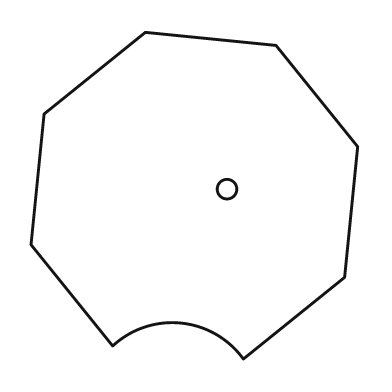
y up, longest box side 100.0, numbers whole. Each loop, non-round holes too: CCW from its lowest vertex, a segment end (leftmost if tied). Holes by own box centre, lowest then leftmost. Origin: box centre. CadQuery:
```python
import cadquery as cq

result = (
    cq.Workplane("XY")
    .moveTo(15.0, -50.0)
    .lineTo(46.0, -25.0)
    .lineTo(50.0, 15.0)
    .lineTo(25.0, 46.0)
    .lineTo(-15.0, 50.0)
    .lineTo(-46.0, 25.0)
    .lineTo(-50.0, -15.0)
    .lineTo(-25.0, -46.0)
    .threePointArc((-4.0, -39.0), (15.0, -50.0))
    .close()
    .moveTo(10.0, 2.0)
    .circle(3.0)
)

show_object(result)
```